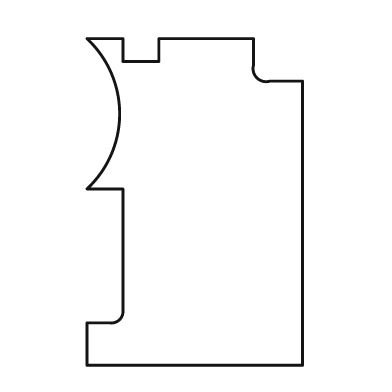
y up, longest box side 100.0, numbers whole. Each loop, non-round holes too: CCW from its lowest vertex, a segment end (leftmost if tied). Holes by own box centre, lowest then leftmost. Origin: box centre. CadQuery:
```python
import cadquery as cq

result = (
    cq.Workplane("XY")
    .moveTo(-33.0, -50.0)
    .lineTo(33.0, -50.0)
    .lineTo(33.0, 37.0)
    .lineTo(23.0, 37.0)
    .threePointArc((19.0, 38.0), (18.0, 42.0))
    .lineTo(18.0, 50.0)
    .lineTo(-11.0, 50.0)
    .lineTo(-11.0, 43.0)
    .lineTo(-22.0, 43.0)
    .lineTo(-22.0, 50.0)
    .lineTo(-33.0, 50.0)
    .threePointArc((-23.0, 27.0), (-33.0, 4.0))
    .lineTo(-22.0, 4.0)
    .lineTo(-22.0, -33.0)
    .threePointArc((-23.0, -36.0), (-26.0, -37.0))
    .lineTo(-33.0, -37.0)
    .close()
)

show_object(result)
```